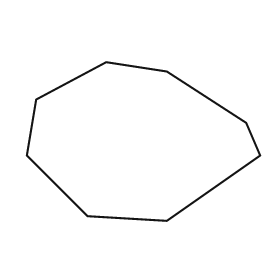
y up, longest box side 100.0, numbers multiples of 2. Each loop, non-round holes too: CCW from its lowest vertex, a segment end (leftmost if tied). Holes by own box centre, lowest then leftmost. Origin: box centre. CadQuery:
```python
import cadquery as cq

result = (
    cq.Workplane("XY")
    .moveTo(10.0, -34.0)
    .lineTo(50.0, -6.0)
    .lineTo(44.0, 8.0)
    .lineTo(10.0, 30.0)
    .lineTo(-16.0, 34.0)
    .lineTo(-46.0, 18.0)
    .lineTo(-50.0, -6.0)
    .lineTo(-24.0, -32.0)
    .close()
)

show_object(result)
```